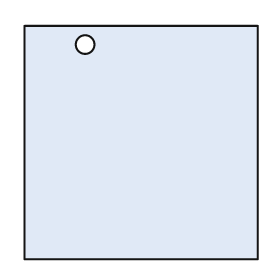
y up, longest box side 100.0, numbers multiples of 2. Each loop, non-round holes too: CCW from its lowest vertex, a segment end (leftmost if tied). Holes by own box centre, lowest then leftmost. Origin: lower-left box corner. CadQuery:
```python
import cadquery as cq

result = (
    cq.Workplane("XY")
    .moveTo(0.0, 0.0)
    .lineTo(100.0, 0.0)
    .lineTo(100.0, 100.0)
    .lineTo(0.0, 100.0)
    .close()
    .moveTo(26.0, 92.0)
    .circle(4.0)
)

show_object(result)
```